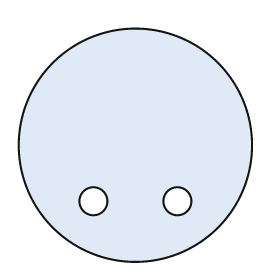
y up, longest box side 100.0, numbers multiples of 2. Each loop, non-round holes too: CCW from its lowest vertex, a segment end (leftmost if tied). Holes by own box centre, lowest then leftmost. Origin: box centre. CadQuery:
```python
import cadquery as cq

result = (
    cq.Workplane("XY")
    .moveTo(0.0, 0.0)
    .circle(50.0)
    .moveTo(-18.0, -24.0)
    .circle(6.0)
    .moveTo(18.0, -24.0)
    .circle(6.0)
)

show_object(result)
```